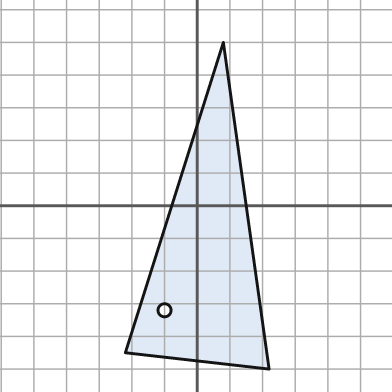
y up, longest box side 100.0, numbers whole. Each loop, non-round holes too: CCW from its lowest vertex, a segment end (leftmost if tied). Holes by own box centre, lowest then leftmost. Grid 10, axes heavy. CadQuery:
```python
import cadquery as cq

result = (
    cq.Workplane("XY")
    .moveTo(22.0, -50.0)
    .lineTo(8.0, 50.0)
    .lineTo(-22.0, -45.0)
    .close()
    .moveTo(-10.0, -32.0)
    .circle(2.0)
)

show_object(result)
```